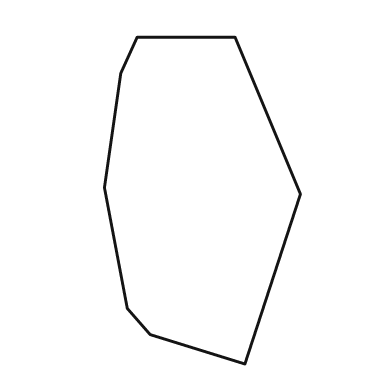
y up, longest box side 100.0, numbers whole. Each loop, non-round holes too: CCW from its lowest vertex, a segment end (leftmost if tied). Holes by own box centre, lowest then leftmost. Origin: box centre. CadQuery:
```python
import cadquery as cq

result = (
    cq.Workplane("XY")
    .moveTo(13.0, -50.0)
    .lineTo(30.0, 2.0)
    .lineTo(10.0, 50.0)
    .lineTo(-20.0, 50.0)
    .lineTo(-25.0, 39.0)
    .lineTo(-30.0, 4.0)
    .lineTo(-23.0, -33.0)
    .lineTo(-16.0, -41.0)
    .close()
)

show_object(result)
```